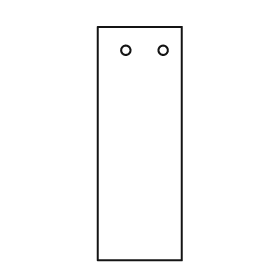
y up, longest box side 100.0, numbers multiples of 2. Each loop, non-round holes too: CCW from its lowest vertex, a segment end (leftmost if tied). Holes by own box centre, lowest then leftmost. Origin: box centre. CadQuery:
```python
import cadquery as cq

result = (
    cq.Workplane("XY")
    .moveTo(-18.0, -50.0)
    .lineTo(18.0, -50.0)
    .lineTo(18.0, 50.0)
    .lineTo(-18.0, 50.0)
    .close()
    .moveTo(-6.0, 40.0)
    .circle(2.0)
    .moveTo(10.0, 40.0)
    .circle(2.0)
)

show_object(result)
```